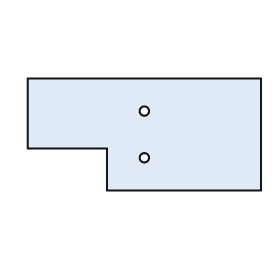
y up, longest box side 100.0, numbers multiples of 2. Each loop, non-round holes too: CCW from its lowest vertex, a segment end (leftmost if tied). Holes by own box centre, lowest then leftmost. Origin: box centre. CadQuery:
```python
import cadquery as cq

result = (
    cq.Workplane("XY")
    .moveTo(-16.0, -24.0)
    .lineTo(50.0, -24.0)
    .lineTo(50.0, 24.0)
    .lineTo(-50.0, 24.0)
    .lineTo(-50.0, -6.0)
    .lineTo(-16.0, -6.0)
    .close()
    .moveTo(0.0, -10.0)
    .circle(2.0)
    .moveTo(0.0, 10.0)
    .circle(2.0)
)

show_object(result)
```